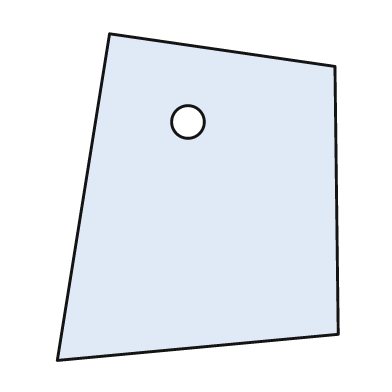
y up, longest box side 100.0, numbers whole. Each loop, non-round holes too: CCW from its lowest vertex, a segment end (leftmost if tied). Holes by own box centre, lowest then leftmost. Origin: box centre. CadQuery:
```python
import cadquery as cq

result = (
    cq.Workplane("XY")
    .moveTo(-43.0, -50.0)
    .lineTo(43.0, -42.0)
    .lineTo(42.0, 40.0)
    .lineTo(-27.0, 50.0)
    .close()
    .moveTo(-3.0, 23.0)
    .circle(5.0)
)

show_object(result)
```